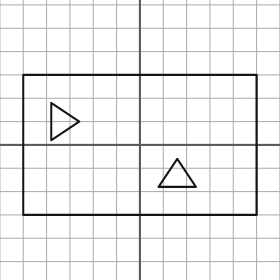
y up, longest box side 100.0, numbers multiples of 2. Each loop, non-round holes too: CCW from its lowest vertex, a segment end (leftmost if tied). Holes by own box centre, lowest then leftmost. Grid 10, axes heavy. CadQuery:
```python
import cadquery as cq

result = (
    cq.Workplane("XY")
    .moveTo(-50.0, -30.0)
    .lineTo(50.0, -30.0)
    .lineTo(50.0, 30.0)
    .lineTo(-50.0, 30.0)
    .close()
    .moveTo(8.0, -18.0)
    .lineTo(24.0, -18.0)
    .lineTo(16.0, -6.0)
    .close()
    .moveTo(-38.0, 2.0)
    .lineTo(-26.0, 10.0)
    .lineTo(-38.0, 18.0)
    .close()
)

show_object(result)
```